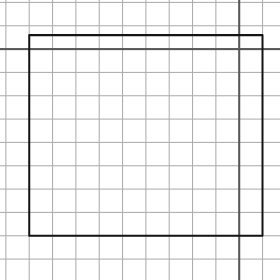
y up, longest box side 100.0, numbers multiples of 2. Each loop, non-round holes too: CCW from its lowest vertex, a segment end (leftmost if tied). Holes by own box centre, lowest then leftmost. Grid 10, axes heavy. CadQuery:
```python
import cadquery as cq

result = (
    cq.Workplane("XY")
    .moveTo(-90.0, -80.0)
    .lineTo(10.0, -80.0)
    .lineTo(10.0, 6.0)
    .lineTo(-90.0, 6.0)
    .close()
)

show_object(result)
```